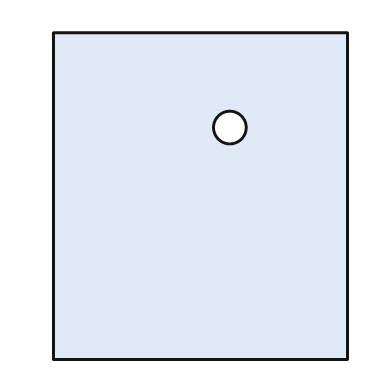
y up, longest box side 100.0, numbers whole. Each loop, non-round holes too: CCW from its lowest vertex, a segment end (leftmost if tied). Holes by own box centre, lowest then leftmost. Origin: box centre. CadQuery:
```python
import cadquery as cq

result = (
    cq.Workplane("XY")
    .moveTo(-45.0, -50.0)
    .lineTo(45.0, -50.0)
    .lineTo(45.0, 50.0)
    .lineTo(-45.0, 50.0)
    .close()
    .moveTo(9.0, 21.0)
    .circle(5.0)
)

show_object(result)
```